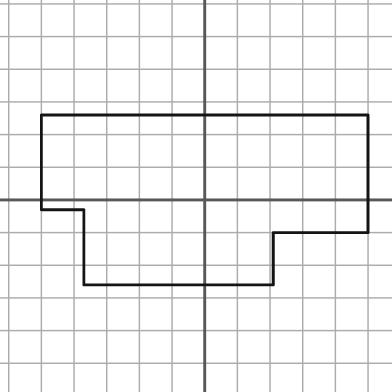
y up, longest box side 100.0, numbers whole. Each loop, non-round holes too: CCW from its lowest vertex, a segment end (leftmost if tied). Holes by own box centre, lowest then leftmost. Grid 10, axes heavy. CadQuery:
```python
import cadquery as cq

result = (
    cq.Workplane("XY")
    .moveTo(-37.0, -26.0)
    .lineTo(21.0, -26.0)
    .lineTo(21.0, -10.0)
    .lineTo(50.0, -10.0)
    .lineTo(50.0, 26.0)
    .lineTo(-50.0, 26.0)
    .lineTo(-50.0, -3.0)
    .lineTo(-37.0, -3.0)
    .close()
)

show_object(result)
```